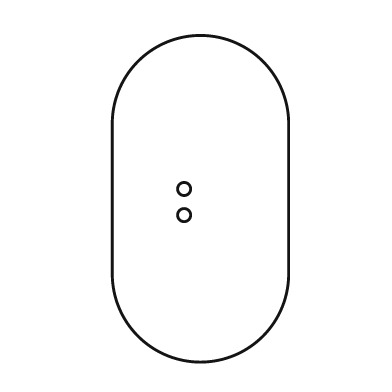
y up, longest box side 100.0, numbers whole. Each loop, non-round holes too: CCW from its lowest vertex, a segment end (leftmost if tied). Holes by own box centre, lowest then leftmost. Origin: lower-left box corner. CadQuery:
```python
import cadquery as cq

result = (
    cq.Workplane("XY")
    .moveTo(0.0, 27.0)
    .threePointArc((27.0, 0.0), (54.0, 27.0))
    .lineTo(54.0, 73.0)
    .threePointArc((27.0, 100.0), (0.0, 73.0))
    .close()
    .moveTo(22.0, 45.0)
    .circle(2.0)
    .moveTo(22.0, 53.0)
    .circle(2.0)
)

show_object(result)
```